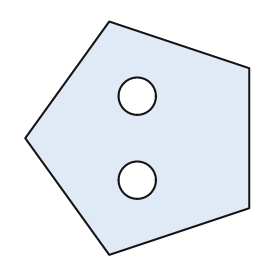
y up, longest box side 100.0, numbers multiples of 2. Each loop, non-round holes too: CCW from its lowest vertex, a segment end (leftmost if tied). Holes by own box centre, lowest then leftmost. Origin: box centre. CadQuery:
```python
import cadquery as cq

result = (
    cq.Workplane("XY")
    .moveTo(-12.0, -50.0)
    .lineTo(48.0, -30.0)
    .lineTo(48.0, 30.0)
    .lineTo(-12.0, 50.0)
    .lineTo(-48.0, 0.0)
    .close()
    .moveTo(0.0, -18.0)
    .circle(8.0)
    .moveTo(0.0, 18.0)
    .circle(8.0)
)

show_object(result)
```